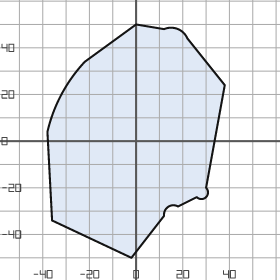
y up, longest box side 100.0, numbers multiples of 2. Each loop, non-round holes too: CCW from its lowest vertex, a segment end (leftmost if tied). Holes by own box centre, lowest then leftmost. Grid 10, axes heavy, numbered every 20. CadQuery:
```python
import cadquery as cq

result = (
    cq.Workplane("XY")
    .moveTo(-2.0, -50.0)
    .lineTo(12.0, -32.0)
    .threePointArc((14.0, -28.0), (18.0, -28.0))
    .lineTo(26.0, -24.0)
    .threePointArc((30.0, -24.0), (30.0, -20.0))
    .lineTo(38.0, 24.0)
    .lineTo(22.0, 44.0)
    .threePointArc((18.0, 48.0), (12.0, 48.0))
    .lineTo(0.0, 50.0)
    .lineTo(-22.0, 34.0)
    .threePointArc((-32.0, 20.0), (-38.0, 4.0))
    .lineTo(-36.0, -34.0)
    .close()
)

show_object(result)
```